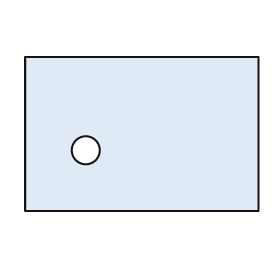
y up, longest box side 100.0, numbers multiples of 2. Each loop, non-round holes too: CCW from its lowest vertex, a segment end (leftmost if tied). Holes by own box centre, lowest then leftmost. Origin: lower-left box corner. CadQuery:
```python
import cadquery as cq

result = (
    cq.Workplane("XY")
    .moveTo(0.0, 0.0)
    .lineTo(100.0, 0.0)
    .lineTo(100.0, 66.0)
    .lineTo(0.0, 66.0)
    .close()
    .moveTo(26.0, 26.0)
    .circle(6.0)
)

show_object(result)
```